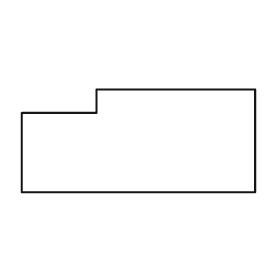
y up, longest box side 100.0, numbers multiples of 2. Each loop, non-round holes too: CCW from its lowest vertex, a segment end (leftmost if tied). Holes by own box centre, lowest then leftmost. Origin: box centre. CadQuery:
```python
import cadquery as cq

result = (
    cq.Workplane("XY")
    .moveTo(-50.0, -22.0)
    .lineTo(50.0, -22.0)
    .lineTo(50.0, 22.0)
    .lineTo(-18.0, 22.0)
    .lineTo(-18.0, 12.0)
    .lineTo(-50.0, 12.0)
    .close()
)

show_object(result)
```